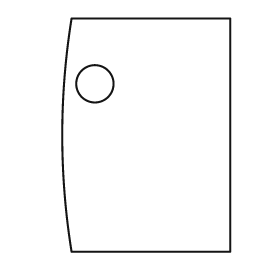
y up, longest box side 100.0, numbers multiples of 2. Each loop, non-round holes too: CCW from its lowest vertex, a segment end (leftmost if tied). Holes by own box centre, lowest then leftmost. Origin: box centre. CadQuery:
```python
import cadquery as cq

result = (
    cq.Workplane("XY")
    .moveTo(-32.0, -50.0)
    .lineTo(36.0, -50.0)
    .lineTo(36.0, 50.0)
    .lineTo(-32.0, 50.0)
    .threePointArc((-36.0, 0.0), (-32.0, -50.0))
    .close()
    .moveTo(-22.0, 22.0)
    .circle(8.0)
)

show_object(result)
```